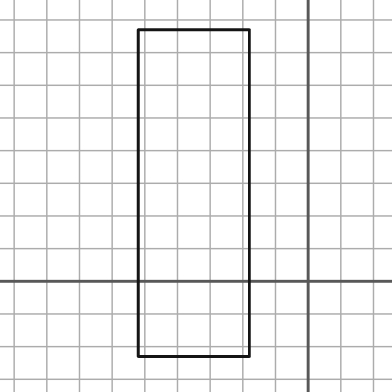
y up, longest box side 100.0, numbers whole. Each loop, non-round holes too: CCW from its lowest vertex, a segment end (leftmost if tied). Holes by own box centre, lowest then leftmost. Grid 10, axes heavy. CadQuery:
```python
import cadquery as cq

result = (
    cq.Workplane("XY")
    .moveTo(-52.0, -23.0)
    .lineTo(-18.0, -23.0)
    .lineTo(-18.0, 77.0)
    .lineTo(-52.0, 77.0)
    .close()
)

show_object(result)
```